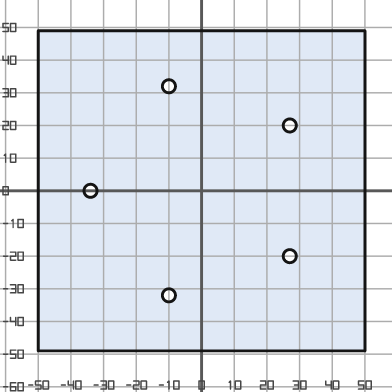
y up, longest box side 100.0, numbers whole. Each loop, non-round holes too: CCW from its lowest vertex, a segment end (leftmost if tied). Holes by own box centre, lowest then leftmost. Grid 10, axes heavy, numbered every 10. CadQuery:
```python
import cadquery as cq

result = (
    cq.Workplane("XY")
    .moveTo(-50.0, -49.0)
    .lineTo(50.0, -49.0)
    .lineTo(50.0, 49.0)
    .lineTo(-50.0, 49.0)
    .close()
    .moveTo(-10.0, -32.0)
    .circle(2.0)
    .moveTo(27.0, -20.0)
    .circle(2.0)
    .moveTo(-34.0, 0.0)
    .circle(2.0)
    .moveTo(27.0, 20.0)
    .circle(2.0)
    .moveTo(-10.0, 32.0)
    .circle(2.0)
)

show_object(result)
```